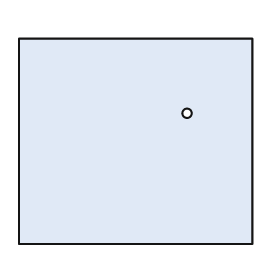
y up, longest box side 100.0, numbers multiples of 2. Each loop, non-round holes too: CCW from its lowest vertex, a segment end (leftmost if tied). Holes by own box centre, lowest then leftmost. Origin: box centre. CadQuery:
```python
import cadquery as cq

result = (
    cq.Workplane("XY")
    .moveTo(-50.0, -44.0)
    .lineTo(50.0, -44.0)
    .lineTo(50.0, 44.0)
    .lineTo(-50.0, 44.0)
    .close()
    .moveTo(22.0, 12.0)
    .circle(2.0)
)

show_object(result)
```